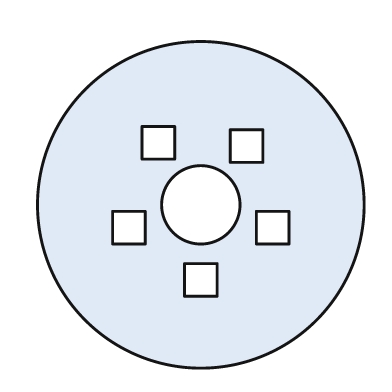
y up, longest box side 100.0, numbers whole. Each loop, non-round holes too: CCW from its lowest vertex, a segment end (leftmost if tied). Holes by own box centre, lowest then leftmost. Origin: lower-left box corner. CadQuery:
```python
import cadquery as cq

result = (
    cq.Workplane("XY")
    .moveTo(50.0, 50.0)
    .circle(50.0)
    .moveTo(45.0, 22.0)
    .lineTo(55.0, 22.0)
    .lineTo(55.0, 32.0)
    .lineTo(45.0, 32.0)
    .close()
    .moveTo(23.0, 38.0)
    .lineTo(33.0, 38.0)
    .lineTo(33.0, 48.0)
    .lineTo(23.0, 48.0)
    .close()
    .moveTo(67.0, 38.0)
    .lineTo(77.0, 38.0)
    .lineTo(77.0, 48.0)
    .lineTo(67.0, 48.0)
    .close()
    .moveTo(50.0, 50.0)
    .circle(12.0)
    .moveTo(59.0, 63.0)
    .lineTo(69.0, 63.0)
    .lineTo(69.0, 73.0)
    .lineTo(59.0, 73.0)
    .close()
    .moveTo(32.0, 64.0)
    .lineTo(42.0, 64.0)
    .lineTo(42.0, 74.0)
    .lineTo(32.0, 74.0)
    .close()
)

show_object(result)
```